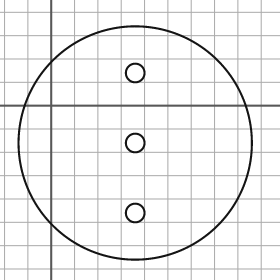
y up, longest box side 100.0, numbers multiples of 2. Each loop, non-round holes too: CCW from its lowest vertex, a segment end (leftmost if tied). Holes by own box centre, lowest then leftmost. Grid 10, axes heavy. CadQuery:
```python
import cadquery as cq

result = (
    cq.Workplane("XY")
    .moveTo(36.0, -16.0)
    .circle(50.0)
    .moveTo(36.0, -46.0)
    .circle(4.0)
    .moveTo(36.0, -16.0)
    .circle(4.0)
    .moveTo(36.0, 14.0)
    .circle(4.0)
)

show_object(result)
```